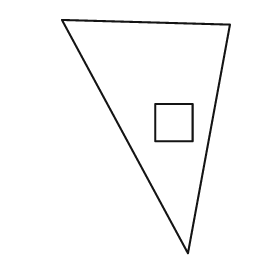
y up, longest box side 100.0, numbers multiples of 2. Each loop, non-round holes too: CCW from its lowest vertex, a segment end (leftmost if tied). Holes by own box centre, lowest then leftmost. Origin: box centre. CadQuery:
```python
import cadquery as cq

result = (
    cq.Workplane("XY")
    .moveTo(18.0, -50.0)
    .lineTo(36.0, 48.0)
    .lineTo(-36.0, 50.0)
    .close()
    .moveTo(4.0, -2.0)
    .lineTo(20.0, -2.0)
    .lineTo(20.0, 14.0)
    .lineTo(4.0, 14.0)
    .close()
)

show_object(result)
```